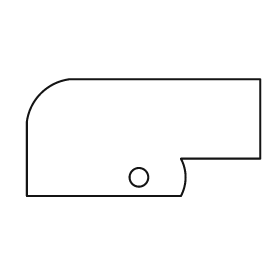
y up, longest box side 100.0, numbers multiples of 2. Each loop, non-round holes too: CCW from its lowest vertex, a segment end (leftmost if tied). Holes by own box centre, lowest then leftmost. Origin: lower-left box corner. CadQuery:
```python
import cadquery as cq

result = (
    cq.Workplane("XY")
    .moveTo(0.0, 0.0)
    .lineTo(66.0, 0.0)
    .threePointArc((68.0, 8.0), (66.0, 16.0))
    .lineTo(100.0, 16.0)
    .lineTo(100.0, 50.0)
    .lineTo(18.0, 50.0)
    .threePointArc((6.0, 44.0), (0.0, 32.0))
    .close()
    .moveTo(48.0, 8.0)
    .circle(4.0)
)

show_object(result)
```